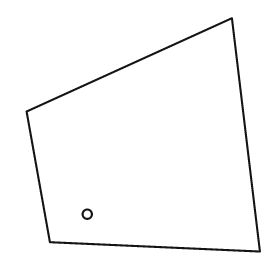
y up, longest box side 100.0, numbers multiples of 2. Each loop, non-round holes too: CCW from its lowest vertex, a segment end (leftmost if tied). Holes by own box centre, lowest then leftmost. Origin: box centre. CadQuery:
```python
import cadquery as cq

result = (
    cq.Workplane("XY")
    .moveTo(50.0, -50.0)
    .lineTo(38.0, 50.0)
    .lineTo(-50.0, 10.0)
    .lineTo(-40.0, -46.0)
    .close()
    .moveTo(-24.0, -34.0)
    .circle(2.0)
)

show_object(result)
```